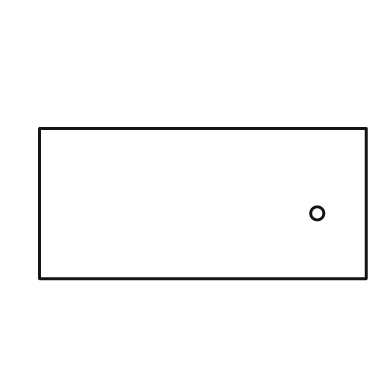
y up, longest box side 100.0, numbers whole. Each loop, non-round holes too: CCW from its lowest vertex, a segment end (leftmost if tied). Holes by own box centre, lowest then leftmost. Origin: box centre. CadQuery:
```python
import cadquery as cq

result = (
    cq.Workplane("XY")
    .moveTo(-50.0, -23.0)
    .lineTo(50.0, -23.0)
    .lineTo(50.0, 23.0)
    .lineTo(-50.0, 23.0)
    .close()
    .moveTo(35.0, -3.0)
    .circle(2.0)
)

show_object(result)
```